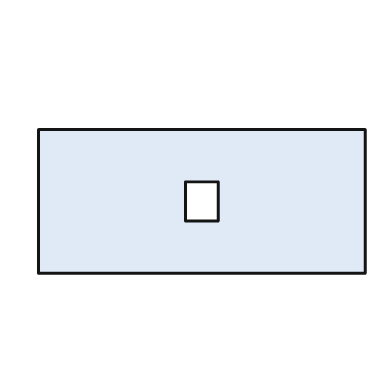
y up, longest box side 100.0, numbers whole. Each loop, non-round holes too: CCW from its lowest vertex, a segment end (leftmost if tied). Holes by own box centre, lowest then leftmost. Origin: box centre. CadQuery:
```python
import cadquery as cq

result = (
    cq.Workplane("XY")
    .moveTo(-50.0, -22.0)
    .lineTo(50.0, -22.0)
    .lineTo(50.0, 22.0)
    .lineTo(-50.0, 22.0)
    .close()
    .moveTo(-5.0, -6.0)
    .lineTo(5.0, -6.0)
    .lineTo(5.0, 6.0)
    .lineTo(-5.0, 6.0)
    .close()
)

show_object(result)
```